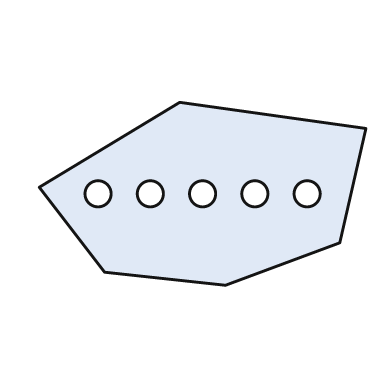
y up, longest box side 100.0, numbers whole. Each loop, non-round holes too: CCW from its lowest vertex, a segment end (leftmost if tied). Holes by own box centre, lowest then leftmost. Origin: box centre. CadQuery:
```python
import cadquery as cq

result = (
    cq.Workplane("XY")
    .moveTo(7.0, -28.0)
    .lineTo(42.0, -15.0)
    .lineTo(50.0, 20.0)
    .lineTo(-7.0, 28.0)
    .lineTo(-50.0, 2.0)
    .lineTo(-30.0, -24.0)
    .close()
    .moveTo(-32.0, 0.0)
    .circle(4.0)
    .moveTo(-16.0, 0.0)
    .circle(4.0)
    .moveTo(0.0, 0.0)
    .circle(4.0)
    .moveTo(16.0, 0.0)
    .circle(4.0)
    .moveTo(32.0, 0.0)
    .circle(4.0)
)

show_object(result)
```